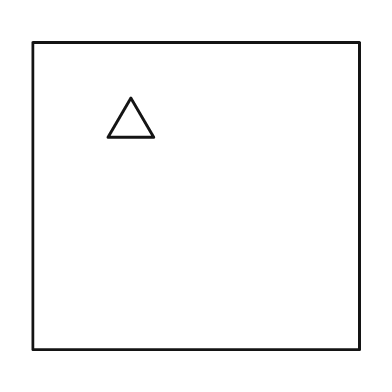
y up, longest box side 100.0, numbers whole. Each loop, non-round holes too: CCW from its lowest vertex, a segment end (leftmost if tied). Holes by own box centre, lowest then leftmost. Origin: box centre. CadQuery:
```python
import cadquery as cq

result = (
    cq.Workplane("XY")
    .moveTo(-50.0, -47.0)
    .lineTo(50.0, -47.0)
    .lineTo(50.0, 47.0)
    .lineTo(-50.0, 47.0)
    .close()
    .moveTo(-27.0, 18.0)
    .lineTo(-13.0, 18.0)
    .lineTo(-20.0, 30.0)
    .close()
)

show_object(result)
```